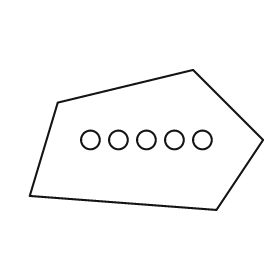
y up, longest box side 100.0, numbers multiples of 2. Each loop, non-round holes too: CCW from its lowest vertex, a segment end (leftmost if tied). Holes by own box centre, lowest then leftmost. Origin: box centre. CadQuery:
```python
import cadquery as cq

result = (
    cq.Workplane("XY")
    .moveTo(30.0, -30.0)
    .lineTo(50.0, 0.0)
    .lineTo(20.0, 30.0)
    .lineTo(-38.0, 16.0)
    .lineTo(-50.0, -24.0)
    .close()
    .moveTo(-24.0, 0.0)
    .circle(4.0)
    .moveTo(-12.0, 0.0)
    .circle(4.0)
    .moveTo(0.0, 0.0)
    .circle(4.0)
    .moveTo(12.0, 0.0)
    .circle(4.0)
    .moveTo(24.0, 0.0)
    .circle(4.0)
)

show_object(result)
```